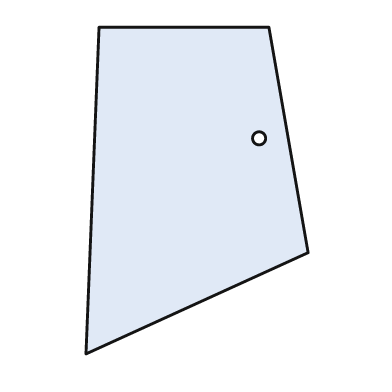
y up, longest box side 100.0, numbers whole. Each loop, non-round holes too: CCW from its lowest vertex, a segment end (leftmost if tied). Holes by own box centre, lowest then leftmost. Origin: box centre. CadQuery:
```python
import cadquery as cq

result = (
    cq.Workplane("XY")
    .moveTo(-34.0, -50.0)
    .lineTo(34.0, -19.0)
    .lineTo(22.0, 50.0)
    .lineTo(-30.0, 50.0)
    .close()
    .moveTo(19.0, 16.0)
    .circle(2.0)
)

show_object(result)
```